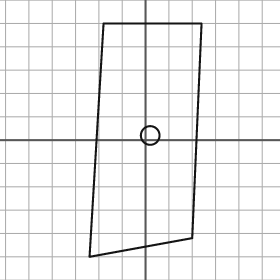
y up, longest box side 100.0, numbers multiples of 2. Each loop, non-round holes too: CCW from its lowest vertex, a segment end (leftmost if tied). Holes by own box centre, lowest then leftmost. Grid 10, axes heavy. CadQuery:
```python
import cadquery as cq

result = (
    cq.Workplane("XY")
    .moveTo(-24.0, -50.0)
    .lineTo(20.0, -42.0)
    .lineTo(24.0, 50.0)
    .lineTo(-18.0, 50.0)
    .close()
    .moveTo(2.0, 2.0)
    .circle(4.0)
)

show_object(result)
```